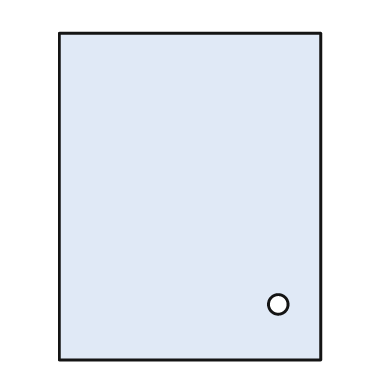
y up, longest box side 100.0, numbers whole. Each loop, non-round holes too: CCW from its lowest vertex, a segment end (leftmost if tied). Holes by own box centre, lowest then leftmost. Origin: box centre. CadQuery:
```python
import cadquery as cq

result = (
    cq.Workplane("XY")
    .moveTo(-40.0, -50.0)
    .lineTo(40.0, -50.0)
    .lineTo(40.0, 50.0)
    .lineTo(-40.0, 50.0)
    .close()
    .moveTo(27.0, -33.0)
    .circle(3.0)
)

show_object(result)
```